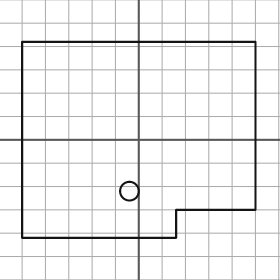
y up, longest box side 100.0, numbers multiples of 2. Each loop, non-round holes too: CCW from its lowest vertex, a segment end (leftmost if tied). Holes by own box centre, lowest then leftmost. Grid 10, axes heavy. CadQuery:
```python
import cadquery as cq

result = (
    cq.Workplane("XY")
    .moveTo(-50.0, -42.0)
    .lineTo(16.0, -42.0)
    .lineTo(16.0, -30.0)
    .lineTo(50.0, -30.0)
    .lineTo(50.0, 42.0)
    .lineTo(-50.0, 42.0)
    .close()
    .moveTo(-4.0, -22.0)
    .circle(4.0)
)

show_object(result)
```